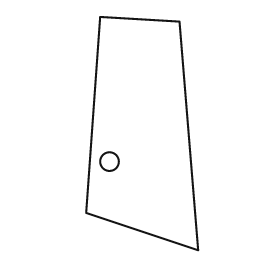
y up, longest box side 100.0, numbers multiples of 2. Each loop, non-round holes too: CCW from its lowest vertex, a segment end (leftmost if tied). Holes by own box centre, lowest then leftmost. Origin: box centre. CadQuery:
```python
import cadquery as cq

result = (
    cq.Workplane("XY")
    .moveTo(24.0, -50.0)
    .lineTo(16.0, 48.0)
    .lineTo(-18.0, 50.0)
    .lineTo(-24.0, -34.0)
    .close()
    .moveTo(-14.0, -12.0)
    .circle(4.0)
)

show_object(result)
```